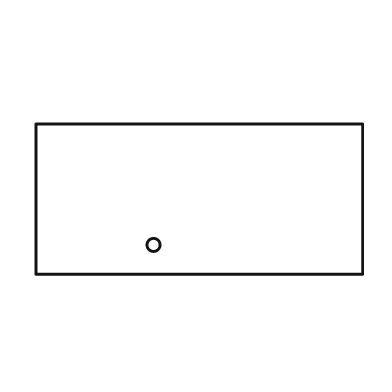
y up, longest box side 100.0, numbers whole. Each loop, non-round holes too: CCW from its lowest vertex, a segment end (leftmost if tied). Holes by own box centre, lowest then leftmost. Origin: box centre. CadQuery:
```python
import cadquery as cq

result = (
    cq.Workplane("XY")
    .moveTo(-50.0, -23.0)
    .lineTo(50.0, -23.0)
    .lineTo(50.0, 23.0)
    .lineTo(-50.0, 23.0)
    .close()
    .moveTo(-14.0, -14.0)
    .circle(2.0)
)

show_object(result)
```